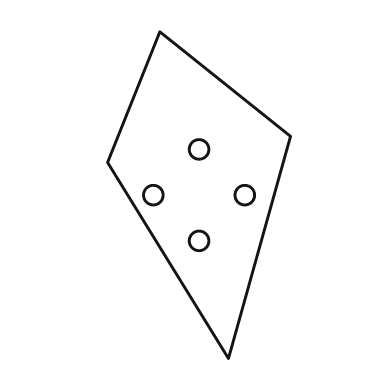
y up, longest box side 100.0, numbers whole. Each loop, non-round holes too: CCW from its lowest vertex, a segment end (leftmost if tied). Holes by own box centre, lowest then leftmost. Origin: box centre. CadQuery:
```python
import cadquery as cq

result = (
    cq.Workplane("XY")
    .moveTo(9.0, -50.0)
    .lineTo(28.0, 18.0)
    .lineTo(-12.0, 50.0)
    .lineTo(-28.0, 10.0)
    .close()
    .moveTo(0.0, -14.0)
    .circle(3.0)
    .moveTo(-14.0, 0.0)
    .circle(3.0)
    .moveTo(14.0, 0.0)
    .circle(3.0)
    .moveTo(0.0, 14.0)
    .circle(3.0)
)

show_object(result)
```